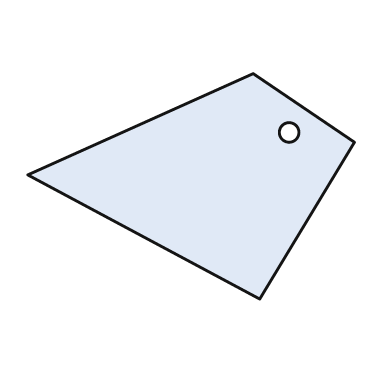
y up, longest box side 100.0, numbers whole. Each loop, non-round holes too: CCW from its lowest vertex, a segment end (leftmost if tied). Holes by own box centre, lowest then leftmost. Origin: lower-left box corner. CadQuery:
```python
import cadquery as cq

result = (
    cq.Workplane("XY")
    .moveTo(71.0, 0.0)
    .lineTo(100.0, 48.0)
    .lineTo(69.0, 69.0)
    .lineTo(0.0, 38.0)
    .close()
    .moveTo(80.0, 51.0)
    .circle(3.0)
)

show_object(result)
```